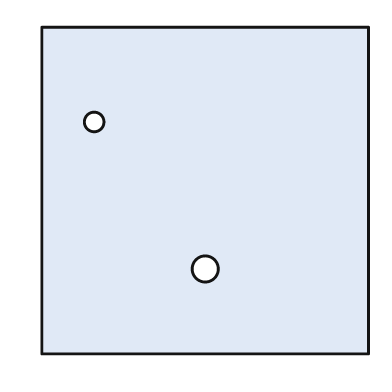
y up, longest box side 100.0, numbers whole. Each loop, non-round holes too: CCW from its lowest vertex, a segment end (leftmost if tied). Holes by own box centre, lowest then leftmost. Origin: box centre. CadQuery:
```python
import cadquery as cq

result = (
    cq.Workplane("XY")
    .moveTo(-50.0, -50.0)
    .lineTo(50.0, -50.0)
    .lineTo(50.0, 50.0)
    .lineTo(-50.0, 50.0)
    .close()
    .moveTo(0.0, -24.0)
    .circle(4.0)
    .moveTo(-34.0, 21.0)
    .circle(3.0)
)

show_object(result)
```